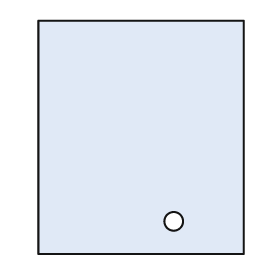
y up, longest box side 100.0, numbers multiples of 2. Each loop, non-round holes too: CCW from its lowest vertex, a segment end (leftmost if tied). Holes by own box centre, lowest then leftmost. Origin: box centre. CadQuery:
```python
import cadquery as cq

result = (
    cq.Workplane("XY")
    .moveTo(-44.0, -50.0)
    .lineTo(44.0, -50.0)
    .lineTo(44.0, 50.0)
    .lineTo(-44.0, 50.0)
    .close()
    .moveTo(14.0, -36.0)
    .circle(4.0)
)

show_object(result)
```